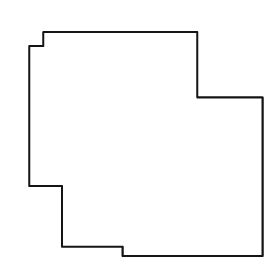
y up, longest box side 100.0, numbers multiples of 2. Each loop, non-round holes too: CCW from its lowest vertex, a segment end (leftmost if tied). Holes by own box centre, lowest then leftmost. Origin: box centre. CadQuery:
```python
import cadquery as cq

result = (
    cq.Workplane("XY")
    .moveTo(-10.0, -48.0)
    .lineTo(50.0, -48.0)
    .lineTo(50.0, 20.0)
    .lineTo(22.0, 20.0)
    .lineTo(22.0, 48.0)
    .lineTo(-44.0, 48.0)
    .lineTo(-44.0, 42.0)
    .lineTo(-50.0, 42.0)
    .lineTo(-50.0, -18.0)
    .lineTo(-36.0, -18.0)
    .lineTo(-36.0, -44.0)
    .lineTo(-10.0, -44.0)
    .close()
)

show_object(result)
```